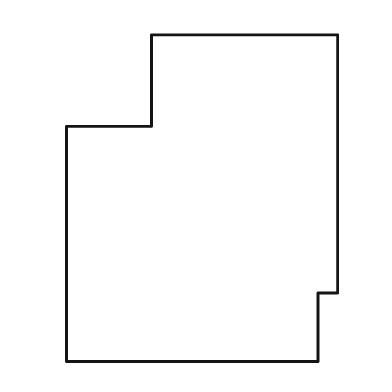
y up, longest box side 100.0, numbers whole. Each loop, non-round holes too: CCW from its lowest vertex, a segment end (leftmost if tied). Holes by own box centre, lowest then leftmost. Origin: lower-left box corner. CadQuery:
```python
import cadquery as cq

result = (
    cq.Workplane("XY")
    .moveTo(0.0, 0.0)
    .lineTo(77.0, 0.0)
    .lineTo(77.0, 21.0)
    .lineTo(83.0, 21.0)
    .lineTo(83.0, 100.0)
    .lineTo(26.0, 100.0)
    .lineTo(26.0, 72.0)
    .lineTo(0.0, 72.0)
    .close()
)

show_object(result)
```